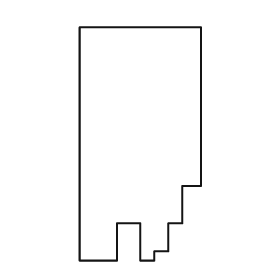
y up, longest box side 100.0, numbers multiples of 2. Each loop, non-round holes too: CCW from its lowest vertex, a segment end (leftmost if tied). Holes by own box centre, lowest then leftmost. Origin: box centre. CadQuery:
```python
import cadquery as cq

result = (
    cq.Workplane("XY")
    .moveTo(-26.0, -50.0)
    .lineTo(-10.0, -50.0)
    .lineTo(-10.0, -34.0)
    .lineTo(0.0, -34.0)
    .lineTo(0.0, -50.0)
    .lineTo(6.0, -50.0)
    .lineTo(6.0, -46.0)
    .lineTo(12.0, -46.0)
    .lineTo(12.0, -34.0)
    .lineTo(18.0, -34.0)
    .lineTo(18.0, -18.0)
    .lineTo(26.0, -18.0)
    .lineTo(26.0, 50.0)
    .lineTo(-26.0, 50.0)
    .close()
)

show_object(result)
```